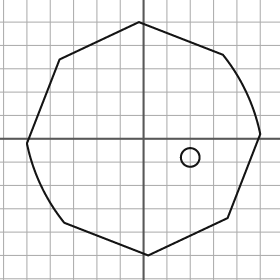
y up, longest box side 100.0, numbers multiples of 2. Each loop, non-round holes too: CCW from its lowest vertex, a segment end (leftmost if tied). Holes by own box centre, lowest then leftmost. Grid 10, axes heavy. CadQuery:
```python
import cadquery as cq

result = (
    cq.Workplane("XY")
    .moveTo(2.0, -50.0)
    .lineTo(36.0, -34.0)
    .lineTo(50.0, 2.0)
    .threePointArc((44.0, 20.0), (34.0, 36.0))
    .lineTo(-2.0, 50.0)
    .lineTo(-36.0, 34.0)
    .lineTo(-50.0, -2.0)
    .threePointArc((-44.0, -20.0), (-34.0, -36.0))
    .close()
    .moveTo(20.0, -8.0)
    .circle(4.0)
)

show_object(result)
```